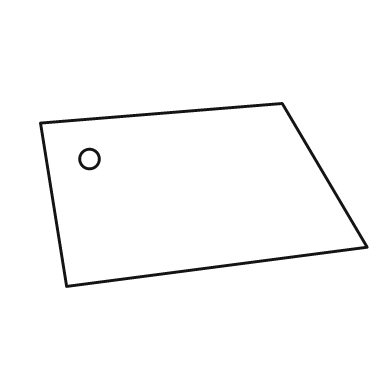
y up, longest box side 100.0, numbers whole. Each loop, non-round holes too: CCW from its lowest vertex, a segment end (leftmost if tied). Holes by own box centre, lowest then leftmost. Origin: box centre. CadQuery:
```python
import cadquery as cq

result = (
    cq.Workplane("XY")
    .moveTo(-42.0, -28.0)
    .lineTo(50.0, -16.0)
    .lineTo(24.0, 28.0)
    .lineTo(-50.0, 22.0)
    .close()
    .moveTo(-35.0, 11.0)
    .circle(3.0)
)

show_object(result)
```